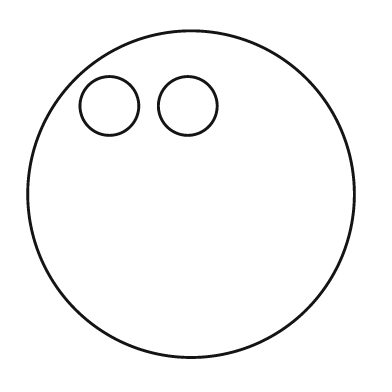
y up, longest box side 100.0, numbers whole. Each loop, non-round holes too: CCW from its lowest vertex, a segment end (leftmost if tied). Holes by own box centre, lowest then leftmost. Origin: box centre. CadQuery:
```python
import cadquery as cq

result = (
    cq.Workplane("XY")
    .moveTo(0.0, 0.0)
    .circle(50.0)
    .moveTo(-25.0, 27.0)
    .circle(9.0)
    .moveTo(-1.0, 27.0)
    .circle(9.0)
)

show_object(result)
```